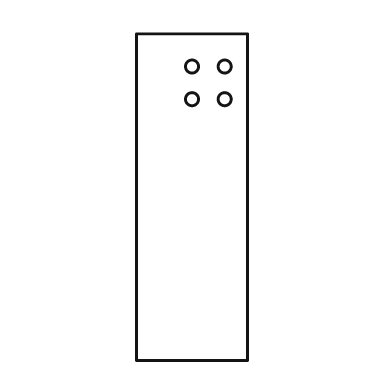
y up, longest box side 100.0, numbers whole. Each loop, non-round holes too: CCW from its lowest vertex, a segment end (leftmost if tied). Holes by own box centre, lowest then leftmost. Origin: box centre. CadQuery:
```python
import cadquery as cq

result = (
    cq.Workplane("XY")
    .moveTo(-17.0, -50.0)
    .lineTo(17.0, -50.0)
    .lineTo(17.0, 50.0)
    .lineTo(-17.0, 50.0)
    .close()
    .moveTo(0.0, 30.0)
    .circle(2.0)
    .moveTo(10.0, 30.0)
    .circle(2.0)
    .moveTo(0.0, 40.0)
    .circle(2.0)
    .moveTo(10.0, 40.0)
    .circle(2.0)
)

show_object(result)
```